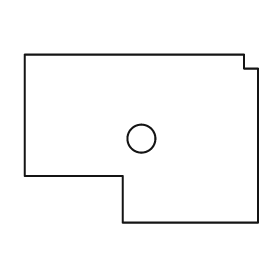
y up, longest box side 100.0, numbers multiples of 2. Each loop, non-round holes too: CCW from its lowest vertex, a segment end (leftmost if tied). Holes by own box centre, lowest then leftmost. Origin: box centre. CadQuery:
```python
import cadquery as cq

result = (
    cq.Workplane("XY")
    .moveTo(-8.0, -36.0)
    .lineTo(50.0, -36.0)
    .lineTo(50.0, 30.0)
    .lineTo(44.0, 30.0)
    .lineTo(44.0, 36.0)
    .lineTo(-50.0, 36.0)
    .lineTo(-50.0, -16.0)
    .lineTo(-8.0, -16.0)
    .close()
    .moveTo(0.0, 0.0)
    .circle(6.0)
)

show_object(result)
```